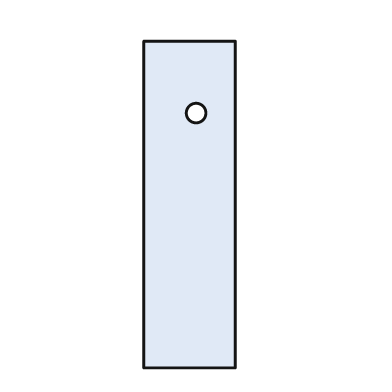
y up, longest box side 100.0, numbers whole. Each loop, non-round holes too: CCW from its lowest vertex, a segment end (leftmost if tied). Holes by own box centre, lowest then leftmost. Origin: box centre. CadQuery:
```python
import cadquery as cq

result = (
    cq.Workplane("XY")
    .moveTo(-14.0, -50.0)
    .lineTo(14.0, -50.0)
    .lineTo(14.0, 50.0)
    .lineTo(-14.0, 50.0)
    .close()
    .moveTo(2.0, 28.0)
    .circle(3.0)
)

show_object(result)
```